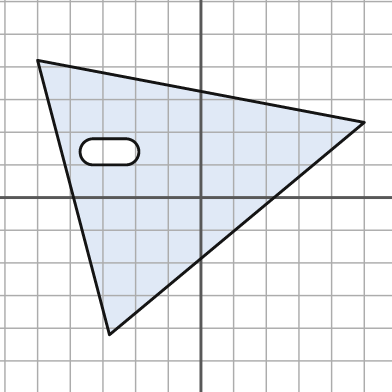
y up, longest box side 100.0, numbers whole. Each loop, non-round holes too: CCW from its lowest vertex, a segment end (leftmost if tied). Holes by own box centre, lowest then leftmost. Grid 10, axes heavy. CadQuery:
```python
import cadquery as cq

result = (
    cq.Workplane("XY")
    .moveTo(-28.0, -42.0)
    .lineTo(50.0, 23.0)
    .lineTo(-50.0, 42.0)
    .close()
    .moveTo(-33.0, 10.0)
    .lineTo(-23.0, 10.0)
    .threePointArc((-19.0, 14.0), (-23.0, 18.0))
    .lineTo(-33.0, 18.0)
    .threePointArc((-37.0, 14.0), (-33.0, 10.0))
    .close()
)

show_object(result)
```